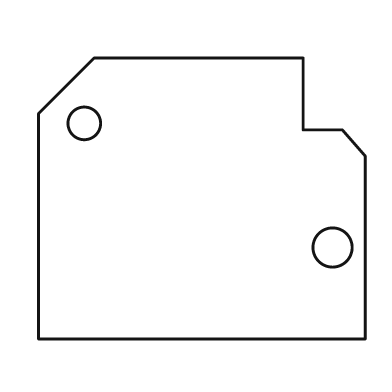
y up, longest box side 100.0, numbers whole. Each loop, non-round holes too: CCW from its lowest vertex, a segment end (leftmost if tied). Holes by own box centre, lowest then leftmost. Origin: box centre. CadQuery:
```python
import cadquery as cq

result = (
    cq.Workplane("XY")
    .moveTo(-50.0, -43.0)
    .lineTo(50.0, -43.0)
    .lineTo(50.0, 13.0)
    .lineTo(43.0, 21.0)
    .lineTo(31.0, 21.0)
    .lineTo(31.0, 43.0)
    .lineTo(-33.0, 43.0)
    .lineTo(-50.0, 26.0)
    .close()
    .moveTo(40.0, -15.0)
    .circle(6.0)
    .moveTo(-36.0, 23.0)
    .circle(5.0)
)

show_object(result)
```